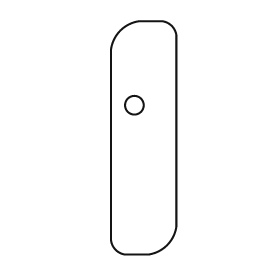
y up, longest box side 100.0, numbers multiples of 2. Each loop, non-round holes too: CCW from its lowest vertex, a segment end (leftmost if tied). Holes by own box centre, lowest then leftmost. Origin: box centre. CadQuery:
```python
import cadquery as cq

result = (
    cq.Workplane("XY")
    .moveTo(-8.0, -50.0)
    .lineTo(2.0, -50.0)
    .threePointArc((10.0, -46.0), (14.0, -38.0))
    .lineTo(14.0, 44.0)
    .threePointArc((12.0, 48.0), (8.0, 50.0))
    .lineTo(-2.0, 50.0)
    .threePointArc((-10.0, 46.0), (-14.0, 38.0))
    .lineTo(-14.0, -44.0)
    .threePointArc((-12.0, -48.0), (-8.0, -50.0))
    .close()
    .moveTo(-4.0, 14.0)
    .circle(4.0)
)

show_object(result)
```